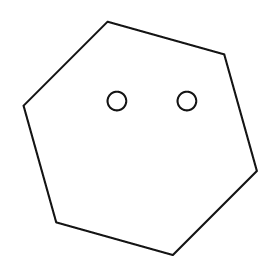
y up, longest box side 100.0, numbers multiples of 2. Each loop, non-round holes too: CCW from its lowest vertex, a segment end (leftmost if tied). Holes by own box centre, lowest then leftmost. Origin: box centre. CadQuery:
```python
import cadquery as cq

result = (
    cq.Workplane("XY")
    .moveTo(14.0, -50.0)
    .lineTo(50.0, -14.0)
    .lineTo(36.0, 36.0)
    .lineTo(-14.0, 50.0)
    .lineTo(-50.0, 14.0)
    .lineTo(-36.0, -36.0)
    .close()
    .moveTo(-10.0, 16.0)
    .circle(4.0)
    .moveTo(20.0, 16.0)
    .circle(4.0)
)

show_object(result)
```